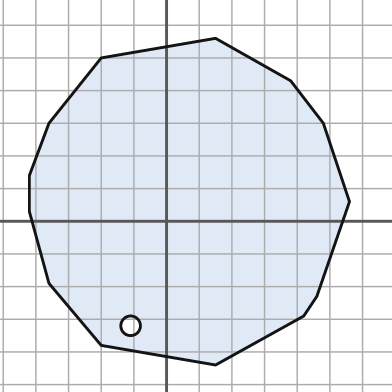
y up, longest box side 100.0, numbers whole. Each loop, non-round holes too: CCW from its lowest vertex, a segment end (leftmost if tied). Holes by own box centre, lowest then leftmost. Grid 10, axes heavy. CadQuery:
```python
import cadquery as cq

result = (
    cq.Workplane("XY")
    .moveTo(15.0, -44.0)
    .lineTo(42.0, -29.0)
    .lineTo(46.0, -23.0)
    .lineTo(56.0, 6.0)
    .lineTo(48.0, 30.0)
    .lineTo(38.0, 43.0)
    .lineTo(15.0, 56.0)
    .lineTo(-20.0, 50.0)
    .lineTo(-36.0, 30.0)
    .lineTo(-42.0, 14.0)
    .lineTo(-42.0, 3.0)
    .lineTo(-36.0, -19.0)
    .lineTo(-20.0, -38.0)
    .close()
    .moveTo(-11.0, -32.0)
    .circle(3.0)
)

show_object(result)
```